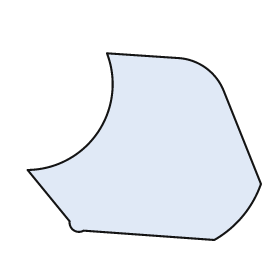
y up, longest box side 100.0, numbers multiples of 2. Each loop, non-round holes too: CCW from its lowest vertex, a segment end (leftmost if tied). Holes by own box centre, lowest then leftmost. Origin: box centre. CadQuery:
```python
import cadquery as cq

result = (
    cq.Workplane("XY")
    .moveTo(30.0, -40.0)
    .threePointArc((42.0, -30.0), (50.0, -16.0))
    .lineTo(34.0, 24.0)
    .threePointArc((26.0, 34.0), (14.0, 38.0))
    .lineTo(-16.0, 40.0)
    .threePointArc((-20.0, 6.0), (-50.0, -10.0))
    .lineTo(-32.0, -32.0)
    .threePointArc((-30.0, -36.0), (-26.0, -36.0))
    .close()
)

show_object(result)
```